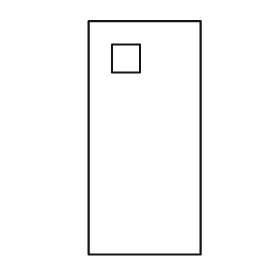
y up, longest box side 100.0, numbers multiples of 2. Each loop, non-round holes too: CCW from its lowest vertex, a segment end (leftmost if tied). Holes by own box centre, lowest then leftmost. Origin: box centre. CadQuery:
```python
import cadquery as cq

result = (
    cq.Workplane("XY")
    .moveTo(-24.0, -50.0)
    .lineTo(24.0, -50.0)
    .lineTo(24.0, 50.0)
    .lineTo(-24.0, 50.0)
    .close()
    .moveTo(-14.0, 28.0)
    .lineTo(-2.0, 28.0)
    .lineTo(-2.0, 40.0)
    .lineTo(-14.0, 40.0)
    .close()
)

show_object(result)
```